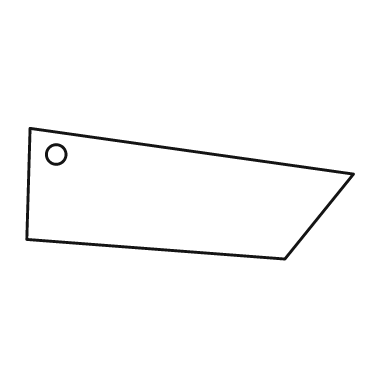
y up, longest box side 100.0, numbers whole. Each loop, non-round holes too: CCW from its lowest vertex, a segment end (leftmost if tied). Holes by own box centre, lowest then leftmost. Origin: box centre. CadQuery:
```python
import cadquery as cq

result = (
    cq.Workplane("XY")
    .moveTo(29.0, -20.0)
    .lineTo(50.0, 6.0)
    .lineTo(-49.0, 20.0)
    .lineTo(-50.0, -14.0)
    .close()
    .moveTo(-41.0, 12.0)
    .circle(3.0)
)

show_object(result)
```